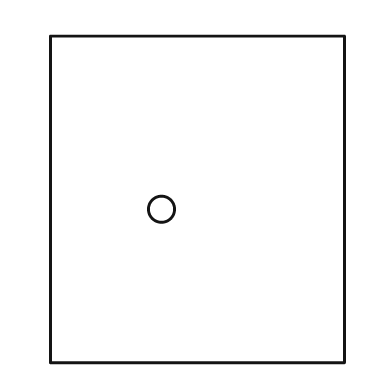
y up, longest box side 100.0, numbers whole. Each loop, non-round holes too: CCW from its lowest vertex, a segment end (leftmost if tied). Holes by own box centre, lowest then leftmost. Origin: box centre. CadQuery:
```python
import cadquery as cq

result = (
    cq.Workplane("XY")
    .moveTo(-45.0, -50.0)
    .lineTo(45.0, -50.0)
    .lineTo(45.0, 50.0)
    .lineTo(-45.0, 50.0)
    .close()
    .moveTo(-11.0, -3.0)
    .circle(4.0)
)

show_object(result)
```